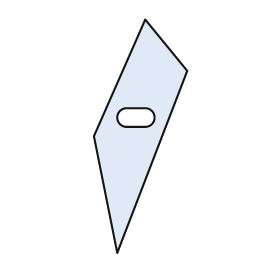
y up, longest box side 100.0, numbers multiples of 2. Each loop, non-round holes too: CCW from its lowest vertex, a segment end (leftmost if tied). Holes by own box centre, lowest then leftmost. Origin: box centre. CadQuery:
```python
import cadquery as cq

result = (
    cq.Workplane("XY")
    .moveTo(-10.0, -50.0)
    .lineTo(20.0, 28.0)
    .lineTo(2.0, 50.0)
    .lineTo(-20.0, 0.0)
    .close()
    .moveTo(-6.0, 4.0)
    .lineTo(2.0, 4.0)
    .threePointArc((6.0, 8.0), (2.0, 12.0))
    .lineTo(-6.0, 12.0)
    .threePointArc((-10.0, 8.0), (-6.0, 4.0))
    .close()
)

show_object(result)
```